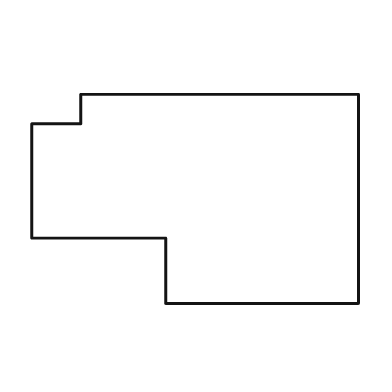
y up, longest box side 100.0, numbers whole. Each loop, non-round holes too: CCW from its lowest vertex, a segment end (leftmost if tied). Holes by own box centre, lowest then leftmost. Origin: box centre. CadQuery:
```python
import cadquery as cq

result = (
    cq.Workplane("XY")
    .moveTo(-9.0, -32.0)
    .lineTo(50.0, -32.0)
    .lineTo(50.0, 32.0)
    .lineTo(-35.0, 32.0)
    .lineTo(-35.0, 23.0)
    .lineTo(-50.0, 23.0)
    .lineTo(-50.0, -12.0)
    .lineTo(-9.0, -12.0)
    .close()
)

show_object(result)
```